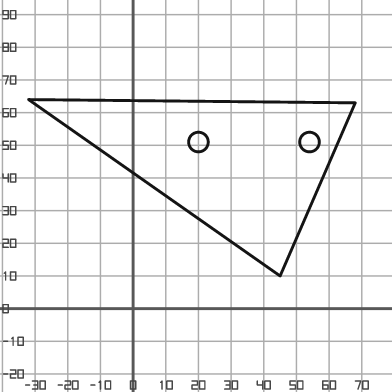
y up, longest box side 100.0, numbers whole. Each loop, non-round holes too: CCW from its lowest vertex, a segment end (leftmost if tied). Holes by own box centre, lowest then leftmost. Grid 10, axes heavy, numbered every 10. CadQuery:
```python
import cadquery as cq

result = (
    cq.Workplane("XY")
    .moveTo(45.0, 10.0)
    .lineTo(68.0, 63.0)
    .lineTo(-32.0, 64.0)
    .close()
    .moveTo(20.0, 51.0)
    .circle(3.0)
    .moveTo(54.0, 51.0)
    .circle(3.0)
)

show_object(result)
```